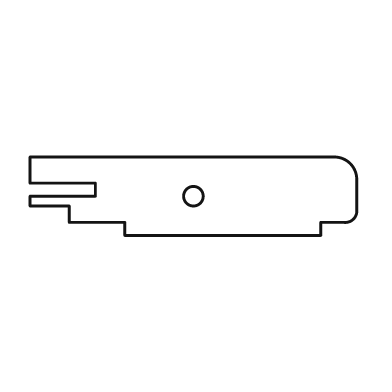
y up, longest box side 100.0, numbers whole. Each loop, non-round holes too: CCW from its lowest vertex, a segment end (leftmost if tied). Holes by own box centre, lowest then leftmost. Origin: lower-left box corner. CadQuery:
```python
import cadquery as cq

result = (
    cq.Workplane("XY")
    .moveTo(29.0, 0.0)
    .lineTo(89.0, 0.0)
    .lineTo(89.0, 4.0)
    .lineTo(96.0, 4.0)
    .threePointArc((99.0, 5.0), (100.0, 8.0))
    .lineTo(100.0, 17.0)
    .threePointArc((98.0, 22.0), (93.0, 24.0))
    .lineTo(0.0, 24.0)
    .lineTo(0.0, 16.0)
    .lineTo(20.0, 16.0)
    .lineTo(20.0, 12.0)
    .lineTo(0.0, 12.0)
    .lineTo(0.0, 9.0)
    .lineTo(12.0, 9.0)
    .lineTo(12.0, 4.0)
    .lineTo(29.0, 4.0)
    .close()
    .moveTo(50.0, 12.0)
    .circle(3.0)
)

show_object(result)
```